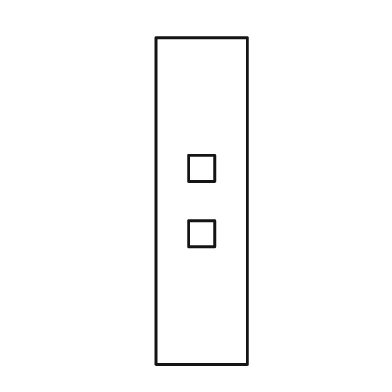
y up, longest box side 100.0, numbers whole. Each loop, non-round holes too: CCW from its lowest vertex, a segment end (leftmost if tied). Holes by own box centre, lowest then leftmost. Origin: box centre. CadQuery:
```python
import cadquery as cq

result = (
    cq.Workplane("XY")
    .moveTo(-14.0, -50.0)
    .lineTo(14.0, -50.0)
    .lineTo(14.0, 50.0)
    .lineTo(-14.0, 50.0)
    .close()
    .moveTo(-4.0, -14.0)
    .lineTo(4.0, -14.0)
    .lineTo(4.0, -6.0)
    .lineTo(-4.0, -6.0)
    .close()
    .moveTo(-4.0, 6.0)
    .lineTo(4.0, 6.0)
    .lineTo(4.0, 14.0)
    .lineTo(-4.0, 14.0)
    .close()
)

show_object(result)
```